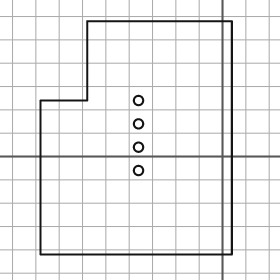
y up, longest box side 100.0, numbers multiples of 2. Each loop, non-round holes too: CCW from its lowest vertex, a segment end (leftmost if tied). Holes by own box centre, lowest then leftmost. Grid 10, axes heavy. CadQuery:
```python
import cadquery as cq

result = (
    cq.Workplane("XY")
    .moveTo(-78.0, -42.0)
    .lineTo(4.0, -42.0)
    .lineTo(4.0, 58.0)
    .lineTo(-58.0, 58.0)
    .lineTo(-58.0, 24.0)
    .lineTo(-78.0, 24.0)
    .close()
    .moveTo(-36.0, -6.0)
    .circle(2.0)
    .moveTo(-36.0, 4.0)
    .circle(2.0)
    .moveTo(-36.0, 14.0)
    .circle(2.0)
    .moveTo(-36.0, 24.0)
    .circle(2.0)
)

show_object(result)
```